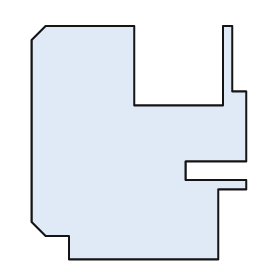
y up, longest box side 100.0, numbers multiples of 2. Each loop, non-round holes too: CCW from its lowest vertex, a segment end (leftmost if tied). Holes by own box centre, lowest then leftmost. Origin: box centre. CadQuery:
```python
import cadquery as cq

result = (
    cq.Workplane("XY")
    .moveTo(-30.0, -50.0)
    .lineTo(34.0, -50.0)
    .lineTo(34.0, -20.0)
    .lineTo(46.0, -20.0)
    .lineTo(46.0, -16.0)
    .lineTo(20.0, -16.0)
    .lineTo(20.0, -8.0)
    .lineTo(46.0, -8.0)
    .lineTo(46.0, 22.0)
    .lineTo(40.0, 22.0)
    .lineTo(40.0, 50.0)
    .lineTo(36.0, 50.0)
    .lineTo(36.0, 16.0)
    .lineTo(-2.0, 16.0)
    .lineTo(-2.0, 50.0)
    .lineTo(-40.0, 50.0)
    .lineTo(-46.0, 44.0)
    .lineTo(-46.0, -34.0)
    .lineTo(-40.0, -40.0)
    .lineTo(-30.0, -40.0)
    .close()
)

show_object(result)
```